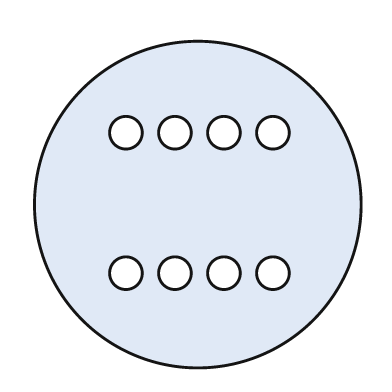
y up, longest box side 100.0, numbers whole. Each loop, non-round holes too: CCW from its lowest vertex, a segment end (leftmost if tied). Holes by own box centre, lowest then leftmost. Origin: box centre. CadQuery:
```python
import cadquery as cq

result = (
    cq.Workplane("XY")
    .moveTo(0.0, 0.0)
    .circle(50.0)
    .moveTo(-22.0, -21.0)
    .circle(5.0)
    .moveTo(-7.0, -21.0)
    .circle(5.0)
    .moveTo(8.0, -21.0)
    .circle(5.0)
    .moveTo(23.0, -21.0)
    .circle(5.0)
    .moveTo(-22.0, 22.0)
    .circle(5.0)
    .moveTo(-7.0, 22.0)
    .circle(5.0)
    .moveTo(8.0, 22.0)
    .circle(5.0)
    .moveTo(23.0, 22.0)
    .circle(5.0)
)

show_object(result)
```